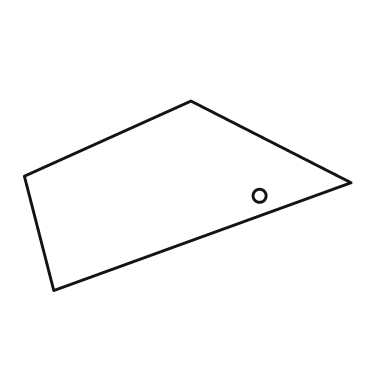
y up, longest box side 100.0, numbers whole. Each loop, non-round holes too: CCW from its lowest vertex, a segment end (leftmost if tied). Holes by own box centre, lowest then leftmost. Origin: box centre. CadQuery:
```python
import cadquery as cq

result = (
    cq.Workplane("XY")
    .moveTo(-41.0, -29.0)
    .lineTo(50.0, 4.0)
    .lineTo(1.0, 29.0)
    .lineTo(-50.0, 6.0)
    .close()
    .moveTo(22.0, 0.0)
    .circle(2.0)
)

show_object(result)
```